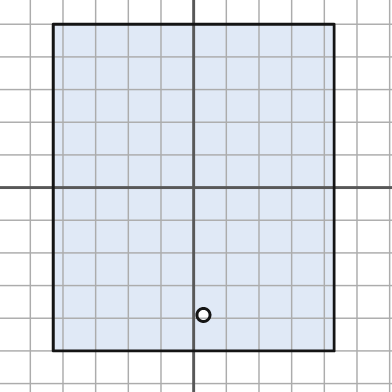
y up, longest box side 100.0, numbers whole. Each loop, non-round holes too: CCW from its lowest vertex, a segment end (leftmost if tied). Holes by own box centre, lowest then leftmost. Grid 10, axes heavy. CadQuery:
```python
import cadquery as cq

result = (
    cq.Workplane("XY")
    .moveTo(-43.0, -50.0)
    .lineTo(43.0, -50.0)
    .lineTo(43.0, 50.0)
    .lineTo(-43.0, 50.0)
    .close()
    .moveTo(3.0, -39.0)
    .circle(2.0)
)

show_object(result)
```